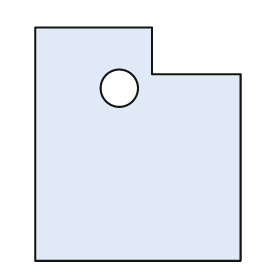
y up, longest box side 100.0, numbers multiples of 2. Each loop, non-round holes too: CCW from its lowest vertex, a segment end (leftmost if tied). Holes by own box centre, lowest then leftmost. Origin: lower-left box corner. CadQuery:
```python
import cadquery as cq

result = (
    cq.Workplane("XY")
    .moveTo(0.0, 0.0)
    .lineTo(88.0, 0.0)
    .lineTo(88.0, 80.0)
    .lineTo(50.0, 80.0)
    .lineTo(50.0, 100.0)
    .lineTo(0.0, 100.0)
    .close()
    .moveTo(36.0, 74.0)
    .circle(8.0)
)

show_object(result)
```